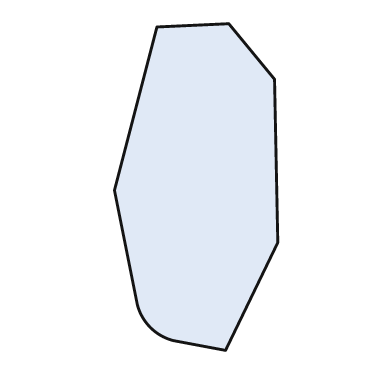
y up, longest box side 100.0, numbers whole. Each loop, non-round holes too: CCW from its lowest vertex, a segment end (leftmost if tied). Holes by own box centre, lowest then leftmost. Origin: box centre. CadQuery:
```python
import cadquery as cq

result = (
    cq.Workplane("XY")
    .moveTo(9.0, -50.0)
    .lineTo(25.0, -17.0)
    .lineTo(24.0, 33.0)
    .lineTo(10.0, 50.0)
    .lineTo(-12.0, 49.0)
    .lineTo(-25.0, -1.0)
    .lineTo(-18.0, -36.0)
    .threePointArc((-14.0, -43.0), (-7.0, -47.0))
    .close()
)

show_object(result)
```